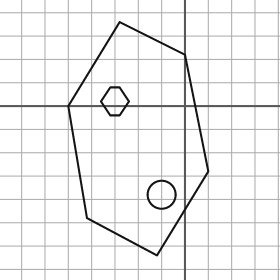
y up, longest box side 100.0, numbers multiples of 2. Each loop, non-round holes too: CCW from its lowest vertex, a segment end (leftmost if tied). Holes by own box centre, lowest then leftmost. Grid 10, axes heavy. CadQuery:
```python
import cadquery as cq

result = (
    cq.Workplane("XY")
    .moveTo(-12.0, -64.0)
    .lineTo(10.0, -28.0)
    .lineTo(0.0, 22.0)
    .lineTo(-28.0, 36.0)
    .lineTo(-50.0, 0.0)
    .lineTo(-42.0, -48.0)
    .close()
    .moveTo(-10.0, -38.0)
    .circle(6.0)
    .moveTo(-32.0, -4.0)
    .lineTo(-28.0, -4.0)
    .lineTo(-24.0, 2.0)
    .lineTo(-28.0, 8.0)
    .lineTo(-32.0, 8.0)
    .lineTo(-36.0, 2.0)
    .close()
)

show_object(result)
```